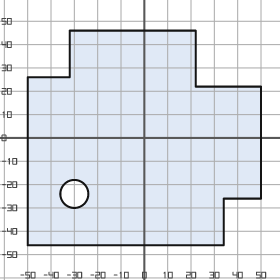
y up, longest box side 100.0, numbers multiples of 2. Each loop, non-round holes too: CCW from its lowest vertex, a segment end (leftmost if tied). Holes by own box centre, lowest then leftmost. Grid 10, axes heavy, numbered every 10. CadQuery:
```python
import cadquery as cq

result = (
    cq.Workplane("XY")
    .moveTo(-50.0, -46.0)
    .lineTo(34.0, -46.0)
    .lineTo(34.0, -26.0)
    .lineTo(50.0, -26.0)
    .lineTo(50.0, 22.0)
    .lineTo(22.0, 22.0)
    .lineTo(22.0, 46.0)
    .lineTo(-32.0, 46.0)
    .lineTo(-32.0, 26.0)
    .lineTo(-50.0, 26.0)
    .close()
    .moveTo(-30.0, -24.0)
    .circle(6.0)
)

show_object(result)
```